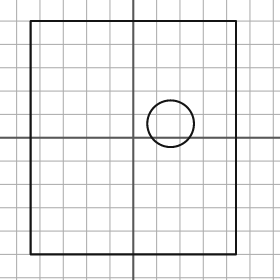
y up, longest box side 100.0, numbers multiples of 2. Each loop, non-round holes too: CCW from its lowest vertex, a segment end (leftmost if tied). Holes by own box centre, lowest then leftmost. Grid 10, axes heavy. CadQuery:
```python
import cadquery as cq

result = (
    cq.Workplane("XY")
    .moveTo(-44.0, -50.0)
    .lineTo(44.0, -50.0)
    .lineTo(44.0, 50.0)
    .lineTo(-44.0, 50.0)
    .close()
    .moveTo(16.0, 6.0)
    .circle(10.0)
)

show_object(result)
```